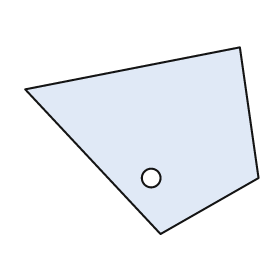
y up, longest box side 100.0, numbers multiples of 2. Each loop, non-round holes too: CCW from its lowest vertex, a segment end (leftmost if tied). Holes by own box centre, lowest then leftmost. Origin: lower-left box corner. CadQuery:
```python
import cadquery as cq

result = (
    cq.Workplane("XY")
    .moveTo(58.0, 0.0)
    .lineTo(100.0, 24.0)
    .lineTo(92.0, 80.0)
    .lineTo(0.0, 62.0)
    .close()
    .moveTo(54.0, 24.0)
    .circle(4.0)
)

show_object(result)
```